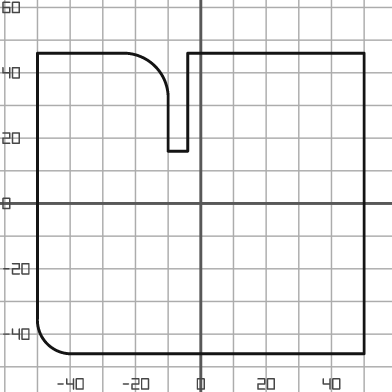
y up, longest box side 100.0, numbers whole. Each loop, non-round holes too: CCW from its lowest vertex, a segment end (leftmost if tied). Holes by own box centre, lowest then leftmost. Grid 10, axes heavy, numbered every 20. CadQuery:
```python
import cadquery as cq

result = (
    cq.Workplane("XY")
    .moveTo(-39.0, -46.0)
    .lineTo(50.0, -46.0)
    .lineTo(50.0, 46.0)
    .lineTo(-4.0, 46.0)
    .lineTo(-4.0, 16.0)
    .lineTo(-10.0, 16.0)
    .lineTo(-10.0, 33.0)
    .threePointArc((-14.0, 42.0), (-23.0, 46.0))
    .lineTo(-50.0, 46.0)
    .lineTo(-50.0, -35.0)
    .threePointArc((-47.0, -43.0), (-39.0, -46.0))
    .close()
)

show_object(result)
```